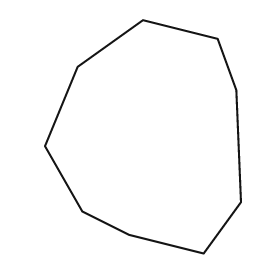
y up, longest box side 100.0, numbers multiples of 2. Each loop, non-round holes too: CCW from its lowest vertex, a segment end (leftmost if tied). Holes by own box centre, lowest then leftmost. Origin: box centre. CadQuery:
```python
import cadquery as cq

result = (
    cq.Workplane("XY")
    .moveTo(26.0, -50.0)
    .lineTo(42.0, -28.0)
    .lineTo(40.0, 20.0)
    .lineTo(32.0, 42.0)
    .lineTo(0.0, 50.0)
    .lineTo(-28.0, 30.0)
    .lineTo(-42.0, -4.0)
    .lineTo(-26.0, -32.0)
    .lineTo(-6.0, -42.0)
    .close()
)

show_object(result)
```